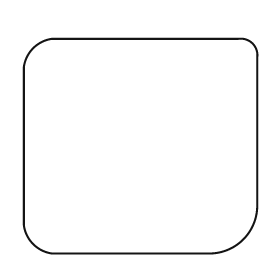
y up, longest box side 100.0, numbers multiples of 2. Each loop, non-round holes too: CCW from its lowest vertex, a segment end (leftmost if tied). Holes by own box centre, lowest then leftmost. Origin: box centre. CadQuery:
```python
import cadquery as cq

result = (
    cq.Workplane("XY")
    .moveTo(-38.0, -46.0)
    .lineTo(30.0, -46.0)
    .threePointArc((44.0, -40.0), (50.0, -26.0))
    .lineTo(50.0, 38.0)
    .threePointArc((48.0, 44.0), (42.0, 46.0))
    .lineTo(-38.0, 46.0)
    .threePointArc((-46.0, 42.0), (-50.0, 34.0))
    .lineTo(-50.0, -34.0)
    .threePointArc((-46.0, -42.0), (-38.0, -46.0))
    .close()
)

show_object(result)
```